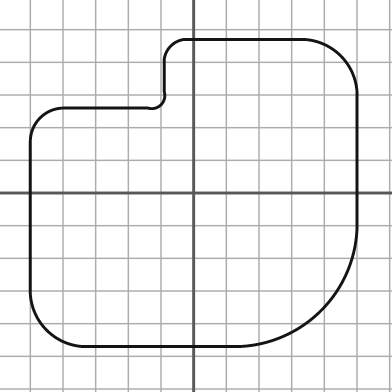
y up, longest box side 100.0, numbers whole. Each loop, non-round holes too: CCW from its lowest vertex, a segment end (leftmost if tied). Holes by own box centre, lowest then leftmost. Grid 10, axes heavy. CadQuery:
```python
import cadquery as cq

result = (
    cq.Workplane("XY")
    .moveTo(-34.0, -47.0)
    .lineTo(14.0, -47.0)
    .threePointArc((39.0, -36.0), (50.0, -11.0))
    .lineTo(50.0, 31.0)
    .threePointArc((45.0, 42.0), (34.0, 47.0))
    .lineTo(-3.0, 47.0)
    .threePointArc((-7.0, 45.0), (-9.0, 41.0))
    .lineTo(-9.0, 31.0)
    .threePointArc((-10.0, 27.0), (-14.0, 26.0))
    .lineTo(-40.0, 26.0)
    .threePointArc((-47.0, 23.0), (-50.0, 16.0))
    .lineTo(-50.0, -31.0)
    .threePointArc((-45.0, -42.0), (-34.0, -47.0))
    .close()
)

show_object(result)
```